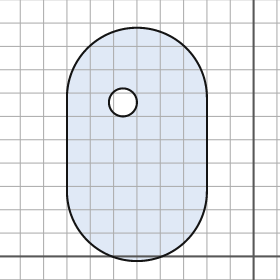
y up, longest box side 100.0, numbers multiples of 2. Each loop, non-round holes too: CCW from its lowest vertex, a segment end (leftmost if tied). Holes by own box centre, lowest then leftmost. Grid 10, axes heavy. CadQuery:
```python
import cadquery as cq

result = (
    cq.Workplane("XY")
    .moveTo(-80.0, 28.0)
    .threePointArc((-50.0, -2.0), (-20.0, 28.0))
    .lineTo(-20.0, 68.0)
    .threePointArc((-50.0, 98.0), (-80.0, 68.0))
    .close()
    .moveTo(-56.0, 66.0)
    .circle(6.0)
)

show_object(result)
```